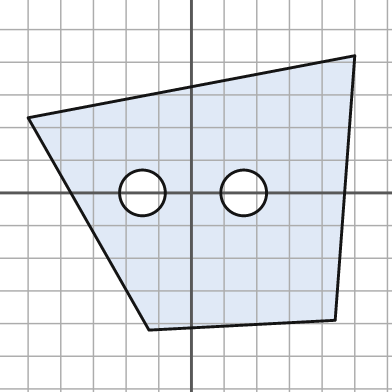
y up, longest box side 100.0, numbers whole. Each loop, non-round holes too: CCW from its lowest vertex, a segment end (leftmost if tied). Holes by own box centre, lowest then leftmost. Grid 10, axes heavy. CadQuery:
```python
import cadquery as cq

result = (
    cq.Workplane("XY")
    .moveTo(-13.0, -42.0)
    .lineTo(44.0, -39.0)
    .lineTo(50.0, 42.0)
    .lineTo(-50.0, 23.0)
    .close()
    .moveTo(-15.0, 0.0)
    .circle(7.0)
    .moveTo(16.0, 0.0)
    .circle(7.0)
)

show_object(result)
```